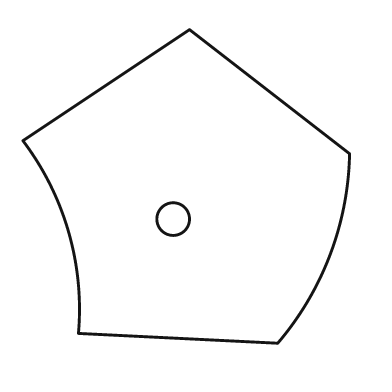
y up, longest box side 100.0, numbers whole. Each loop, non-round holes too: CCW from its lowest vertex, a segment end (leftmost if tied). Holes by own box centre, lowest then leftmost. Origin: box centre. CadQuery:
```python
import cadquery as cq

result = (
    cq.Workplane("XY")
    .moveTo(28.0, -48.0)
    .threePointArc((44.0, -21.0), (50.0, 10.0))
    .lineTo(1.0, 48.0)
    .lineTo(-50.0, 14.0)
    .threePointArc((-36.0, -14.0), (-33.0, -45.0))
    .close()
    .moveTo(-4.0, -10.0)
    .circle(5.0)
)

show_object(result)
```